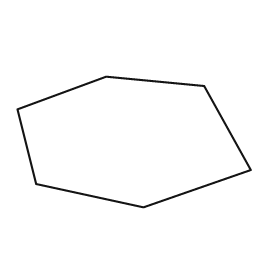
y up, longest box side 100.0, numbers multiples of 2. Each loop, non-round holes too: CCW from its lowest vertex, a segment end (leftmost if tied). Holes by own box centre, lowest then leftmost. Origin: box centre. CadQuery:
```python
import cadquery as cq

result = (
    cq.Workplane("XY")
    .moveTo(4.0, -28.0)
    .lineTo(50.0, -12.0)
    .lineTo(30.0, 24.0)
    .lineTo(-12.0, 28.0)
    .lineTo(-50.0, 14.0)
    .lineTo(-42.0, -18.0)
    .close()
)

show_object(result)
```